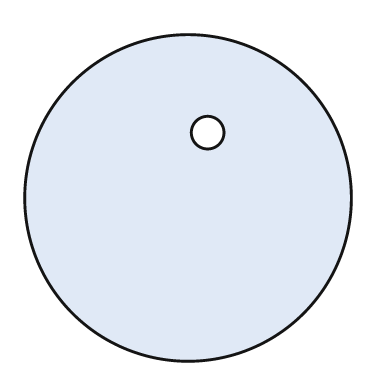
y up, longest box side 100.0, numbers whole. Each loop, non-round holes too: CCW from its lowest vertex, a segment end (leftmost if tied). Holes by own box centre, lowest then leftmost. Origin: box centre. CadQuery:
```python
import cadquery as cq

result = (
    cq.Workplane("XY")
    .moveTo(0.0, 0.0)
    .circle(50.0)
    .moveTo(6.0, 20.0)
    .circle(5.0)
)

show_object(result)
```